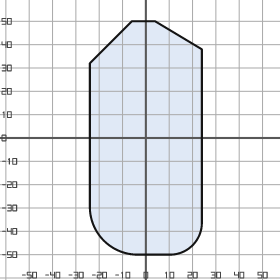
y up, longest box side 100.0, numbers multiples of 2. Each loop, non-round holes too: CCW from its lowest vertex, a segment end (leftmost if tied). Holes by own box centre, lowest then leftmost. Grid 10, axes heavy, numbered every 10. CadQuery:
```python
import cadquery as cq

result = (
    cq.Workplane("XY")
    .moveTo(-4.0, -50.0)
    .lineTo(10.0, -50.0)
    .threePointArc((20.0, -46.0), (24.0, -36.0))
    .lineTo(24.0, 38.0)
    .lineTo(4.0, 50.0)
    .lineTo(-6.0, 50.0)
    .lineTo(-24.0, 32.0)
    .lineTo(-24.0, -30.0)
    .threePointArc((-18.0, -44.0), (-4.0, -50.0))
    .close()
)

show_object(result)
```